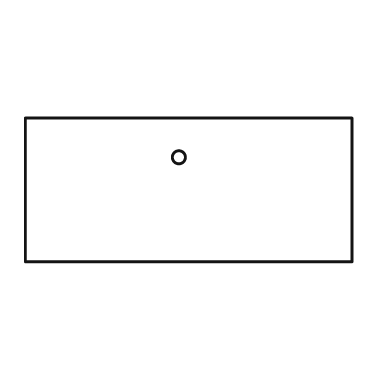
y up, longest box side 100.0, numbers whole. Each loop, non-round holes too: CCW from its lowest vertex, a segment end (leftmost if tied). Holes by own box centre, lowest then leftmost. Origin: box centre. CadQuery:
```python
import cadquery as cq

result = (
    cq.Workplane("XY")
    .moveTo(-50.0, -22.0)
    .lineTo(50.0, -22.0)
    .lineTo(50.0, 22.0)
    .lineTo(-50.0, 22.0)
    .close()
    .moveTo(-3.0, 10.0)
    .circle(2.0)
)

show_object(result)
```